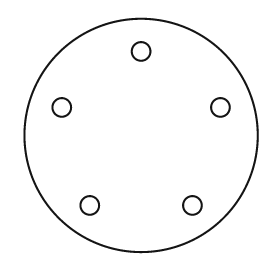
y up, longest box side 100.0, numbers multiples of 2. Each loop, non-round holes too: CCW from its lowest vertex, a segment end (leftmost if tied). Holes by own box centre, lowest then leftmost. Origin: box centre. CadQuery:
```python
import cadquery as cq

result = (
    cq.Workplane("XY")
    .moveTo(0.0, 0.0)
    .circle(50.0)
    .moveTo(-22.0, -30.0)
    .circle(4.0)
    .moveTo(22.0, -30.0)
    .circle(4.0)
    .moveTo(-34.0, 12.0)
    .circle(4.0)
    .moveTo(34.0, 12.0)
    .circle(4.0)
    .moveTo(0.0, 36.0)
    .circle(4.0)
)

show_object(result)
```